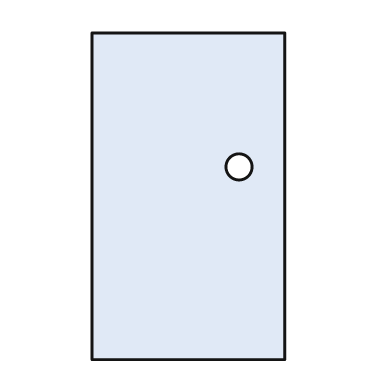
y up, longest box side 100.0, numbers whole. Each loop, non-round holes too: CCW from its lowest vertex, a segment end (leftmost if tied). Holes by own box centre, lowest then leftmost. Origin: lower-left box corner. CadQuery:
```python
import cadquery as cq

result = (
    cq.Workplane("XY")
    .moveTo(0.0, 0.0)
    .lineTo(59.0, 0.0)
    .lineTo(59.0, 100.0)
    .lineTo(0.0, 100.0)
    .close()
    .moveTo(45.0, 59.0)
    .circle(4.0)
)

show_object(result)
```